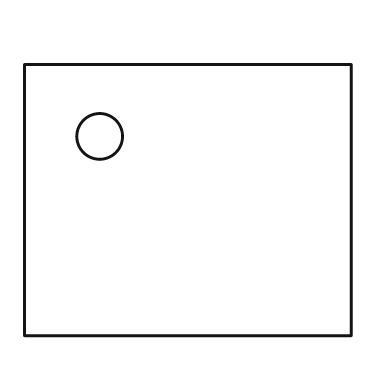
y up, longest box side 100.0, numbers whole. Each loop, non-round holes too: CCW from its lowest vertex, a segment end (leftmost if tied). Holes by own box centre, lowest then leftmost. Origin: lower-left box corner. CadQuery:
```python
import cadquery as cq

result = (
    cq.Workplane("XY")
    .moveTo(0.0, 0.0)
    .lineTo(100.0, 0.0)
    .lineTo(100.0, 83.0)
    .lineTo(0.0, 83.0)
    .close()
    .moveTo(23.0, 61.0)
    .circle(7.0)
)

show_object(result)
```